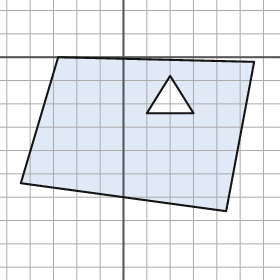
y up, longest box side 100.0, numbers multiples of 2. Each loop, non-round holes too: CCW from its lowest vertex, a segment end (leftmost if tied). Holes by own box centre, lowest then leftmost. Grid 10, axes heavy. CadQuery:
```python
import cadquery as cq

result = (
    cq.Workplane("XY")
    .moveTo(44.0, -66.0)
    .lineTo(56.0, -2.0)
    .lineTo(-28.0, 0.0)
    .lineTo(-44.0, -54.0)
    .close()
    .moveTo(10.0, -24.0)
    .lineTo(30.0, -24.0)
    .lineTo(20.0, -8.0)
    .close()
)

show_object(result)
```